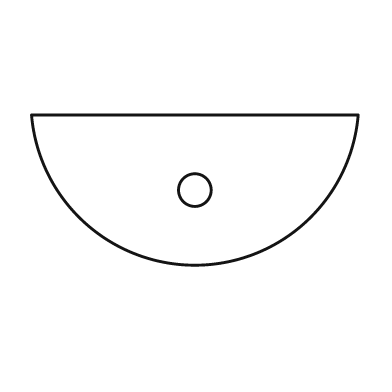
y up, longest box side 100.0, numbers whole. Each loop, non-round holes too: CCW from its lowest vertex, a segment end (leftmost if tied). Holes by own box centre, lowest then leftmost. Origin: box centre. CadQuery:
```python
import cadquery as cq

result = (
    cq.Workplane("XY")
    .moveTo(-50.0, 23.0)
    .threePointArc((0.0, -23.0), (50.0, 23.0))
    .close()
    .moveTo(0.0, 0.0)
    .circle(5.0)
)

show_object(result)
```